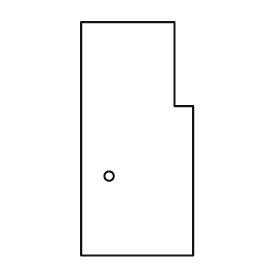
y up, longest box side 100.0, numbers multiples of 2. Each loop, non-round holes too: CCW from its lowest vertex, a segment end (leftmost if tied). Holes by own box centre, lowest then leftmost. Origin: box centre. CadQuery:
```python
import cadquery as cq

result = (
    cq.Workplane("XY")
    .moveTo(-24.0, -50.0)
    .lineTo(24.0, -50.0)
    .lineTo(24.0, 14.0)
    .lineTo(16.0, 14.0)
    .lineTo(16.0, 50.0)
    .lineTo(-24.0, 50.0)
    .close()
    .moveTo(-12.0, -16.0)
    .circle(2.0)
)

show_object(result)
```